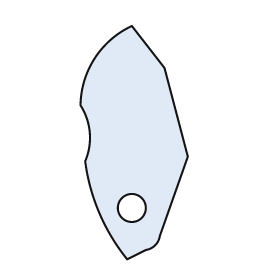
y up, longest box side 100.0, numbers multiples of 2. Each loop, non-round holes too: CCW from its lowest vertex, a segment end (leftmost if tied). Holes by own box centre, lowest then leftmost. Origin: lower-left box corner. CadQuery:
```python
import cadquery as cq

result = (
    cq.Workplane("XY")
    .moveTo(20.0, 0.0)
    .lineTo(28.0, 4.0)
    .threePointArc((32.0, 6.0), (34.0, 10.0))
    .lineTo(46.0, 44.0)
    .lineTo(36.0, 82.0)
    .lineTo(22.0, 100.0)
    .threePointArc((6.0, 86.0), (0.0, 66.0))
    .threePointArc((4.0, 54.0), (2.0, 42.0))
    .threePointArc((8.0, 20.0), (20.0, 0.0))
    .close()
    .moveTo(22.0, 22.0)
    .circle(6.0)
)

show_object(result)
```